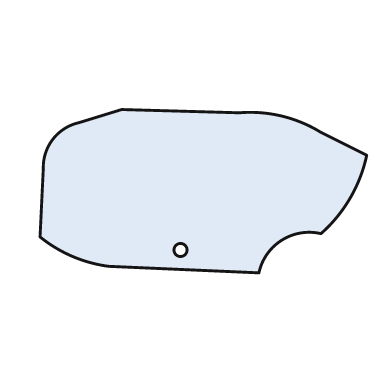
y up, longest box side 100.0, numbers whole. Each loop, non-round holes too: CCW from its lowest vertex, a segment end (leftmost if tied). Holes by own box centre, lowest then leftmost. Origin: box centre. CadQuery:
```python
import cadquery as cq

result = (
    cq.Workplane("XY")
    .moveTo(17.0, -25.0)
    .threePointArc((24.0, -15.0), (36.0, -13.0))
    .threePointArc((45.0, -2.0), (50.0, 11.0))
    .lineTo(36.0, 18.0)
    .threePointArc((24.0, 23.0), (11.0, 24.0))
    .lineTo(-25.0, 25.0)
    .lineTo(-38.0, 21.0)
    .threePointArc((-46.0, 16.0), (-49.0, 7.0))
    .lineTo(-50.0, -14.0)
    .threePointArc((-40.0, -20.0), (-29.0, -23.0))
    .close()
    .moveTo(-7.0, -18.0)
    .circle(2.0)
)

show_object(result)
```